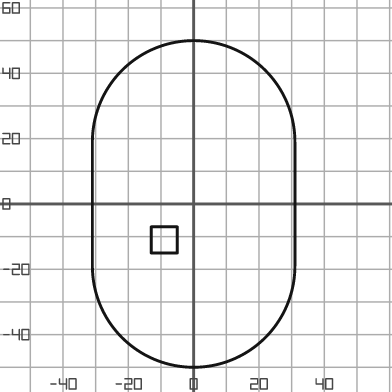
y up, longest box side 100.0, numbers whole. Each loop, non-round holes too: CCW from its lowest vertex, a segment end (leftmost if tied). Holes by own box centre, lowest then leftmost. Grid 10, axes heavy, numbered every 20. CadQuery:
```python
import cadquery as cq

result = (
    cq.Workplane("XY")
    .moveTo(-31.0, -19.0)
    .threePointArc((0.0, -50.0), (31.0, -19.0))
    .lineTo(31.0, 19.0)
    .threePointArc((0.0, 50.0), (-31.0, 19.0))
    .close()
    .moveTo(-13.0, -15.0)
    .lineTo(-5.0, -15.0)
    .lineTo(-5.0, -7.0)
    .lineTo(-13.0, -7.0)
    .close()
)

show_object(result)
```